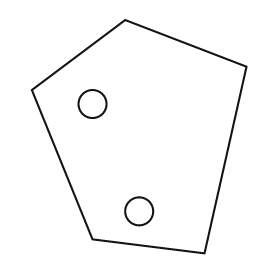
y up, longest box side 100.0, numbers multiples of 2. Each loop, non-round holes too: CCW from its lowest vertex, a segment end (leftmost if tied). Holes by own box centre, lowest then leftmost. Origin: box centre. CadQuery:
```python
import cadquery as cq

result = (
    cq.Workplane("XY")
    .moveTo(28.0, -50.0)
    .lineTo(46.0, 30.0)
    .lineTo(-6.0, 50.0)
    .lineTo(-46.0, 20.0)
    .lineTo(-20.0, -44.0)
    .close()
    .moveTo(0.0, -32.0)
    .circle(6.0)
    .moveTo(-20.0, 14.0)
    .circle(6.0)
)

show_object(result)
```